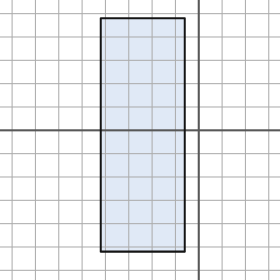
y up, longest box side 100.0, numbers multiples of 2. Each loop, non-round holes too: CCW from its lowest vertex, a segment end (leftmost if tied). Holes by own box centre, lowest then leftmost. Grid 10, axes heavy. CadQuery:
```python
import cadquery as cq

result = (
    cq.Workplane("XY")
    .moveTo(-42.0, -52.0)
    .lineTo(-6.0, -52.0)
    .lineTo(-6.0, 48.0)
    .lineTo(-42.0, 48.0)
    .close()
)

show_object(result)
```